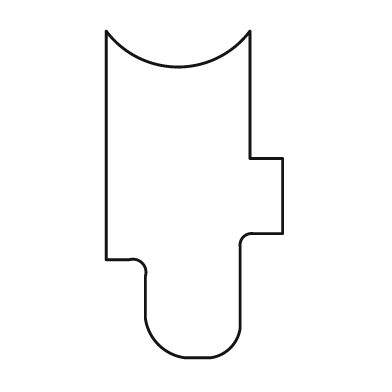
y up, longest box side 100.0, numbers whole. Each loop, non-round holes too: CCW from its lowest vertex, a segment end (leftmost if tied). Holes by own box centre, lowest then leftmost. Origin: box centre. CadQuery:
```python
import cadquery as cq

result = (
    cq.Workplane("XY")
    .moveTo(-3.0, -50.0)
    .lineTo(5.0, -50.0)
    .threePointArc((11.0, -47.0), (14.0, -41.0))
    .lineTo(14.0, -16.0)
    .threePointArc((15.0, -13.0), (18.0, -12.0))
    .lineTo(27.0, -12.0)
    .lineTo(27.0, 11.0)
    .lineTo(17.0, 11.0)
    .lineTo(17.0, 50.0)
    .threePointArc((-5.0, 39.0), (-27.0, 50.0))
    .lineTo(-27.0, -20.0)
    .lineTo(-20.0, -20.0)
    .threePointArc((-16.0, -21.0), (-15.0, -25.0))
    .lineTo(-15.0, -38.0)
    .threePointArc((-11.0, -46.0), (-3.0, -50.0))
    .close()
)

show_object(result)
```